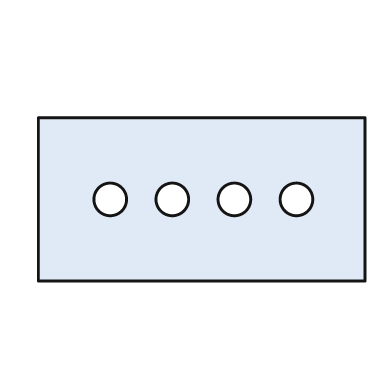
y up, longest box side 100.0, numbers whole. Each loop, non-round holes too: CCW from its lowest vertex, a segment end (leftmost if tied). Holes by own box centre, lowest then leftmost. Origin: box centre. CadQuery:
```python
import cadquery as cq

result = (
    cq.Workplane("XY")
    .moveTo(-50.0, -25.0)
    .lineTo(50.0, -25.0)
    .lineTo(50.0, 25.0)
    .lineTo(-50.0, 25.0)
    .close()
    .moveTo(-28.0, 0.0)
    .circle(5.0)
    .moveTo(-9.0, 0.0)
    .circle(5.0)
    .moveTo(10.0, 0.0)
    .circle(5.0)
    .moveTo(29.0, 0.0)
    .circle(5.0)
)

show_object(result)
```